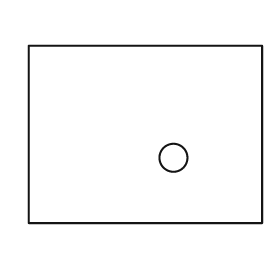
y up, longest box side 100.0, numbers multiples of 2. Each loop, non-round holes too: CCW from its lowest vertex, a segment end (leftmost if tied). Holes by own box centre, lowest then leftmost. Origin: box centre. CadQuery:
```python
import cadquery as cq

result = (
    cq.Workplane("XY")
    .moveTo(-50.0, -38.0)
    .lineTo(50.0, -38.0)
    .lineTo(50.0, 38.0)
    .lineTo(-50.0, 38.0)
    .close()
    .moveTo(12.0, -10.0)
    .circle(6.0)
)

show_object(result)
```